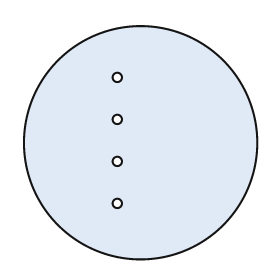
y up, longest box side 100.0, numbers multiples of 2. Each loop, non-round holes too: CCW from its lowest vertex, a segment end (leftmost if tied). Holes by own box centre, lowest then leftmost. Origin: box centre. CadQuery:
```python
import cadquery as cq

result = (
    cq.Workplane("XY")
    .moveTo(0.0, 0.0)
    .circle(50.0)
    .moveTo(-10.0, -26.0)
    .circle(2.0)
    .moveTo(-10.0, -8.0)
    .circle(2.0)
    .moveTo(-10.0, 10.0)
    .circle(2.0)
    .moveTo(-10.0, 28.0)
    .circle(2.0)
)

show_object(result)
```